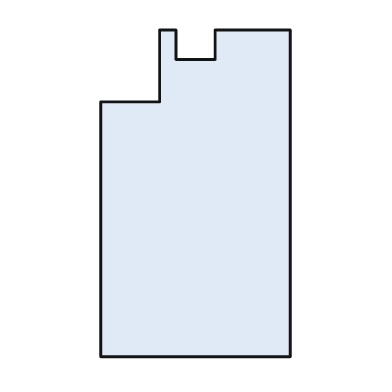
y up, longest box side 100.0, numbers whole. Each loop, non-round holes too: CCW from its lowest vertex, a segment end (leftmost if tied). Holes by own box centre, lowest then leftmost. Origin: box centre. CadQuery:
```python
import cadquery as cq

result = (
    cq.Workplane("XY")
    .moveTo(-29.0, -50.0)
    .lineTo(29.0, -50.0)
    .lineTo(29.0, 50.0)
    .lineTo(6.0, 50.0)
    .lineTo(6.0, 41.0)
    .lineTo(-6.0, 41.0)
    .lineTo(-6.0, 50.0)
    .lineTo(-11.0, 50.0)
    .lineTo(-11.0, 28.0)
    .lineTo(-29.0, 28.0)
    .close()
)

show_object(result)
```